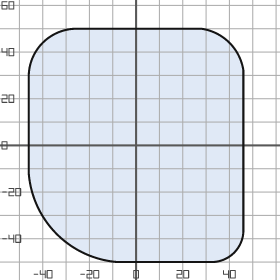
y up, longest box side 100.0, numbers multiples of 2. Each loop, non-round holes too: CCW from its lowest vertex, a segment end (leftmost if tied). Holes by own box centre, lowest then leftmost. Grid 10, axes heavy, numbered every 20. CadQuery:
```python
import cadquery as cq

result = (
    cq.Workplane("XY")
    .moveTo(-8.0, -50.0)
    .lineTo(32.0, -50.0)
    .threePointArc((42.0, -46.0), (46.0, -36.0))
    .lineTo(46.0, 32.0)
    .threePointArc((40.0, 44.0), (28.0, 50.0))
    .lineTo(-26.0, 50.0)
    .threePointArc((-40.0, 44.0), (-46.0, 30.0))
    .lineTo(-46.0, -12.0)
    .threePointArc((-34.0, -38.0), (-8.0, -50.0))
    .close()
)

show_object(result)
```